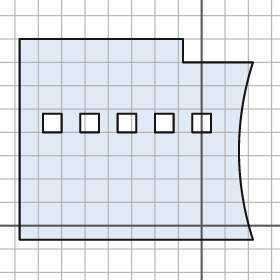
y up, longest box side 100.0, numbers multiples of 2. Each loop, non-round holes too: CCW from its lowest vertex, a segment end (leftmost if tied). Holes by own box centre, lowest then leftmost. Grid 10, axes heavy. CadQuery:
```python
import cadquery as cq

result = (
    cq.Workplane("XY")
    .moveTo(-78.0, -6.0)
    .lineTo(22.0, -6.0)
    .threePointArc((16.0, 32.0), (22.0, 70.0))
    .lineTo(-8.0, 70.0)
    .lineTo(-8.0, 80.0)
    .lineTo(-78.0, 80.0)
    .close()
    .moveTo(-68.0, 40.0)
    .lineTo(-60.0, 40.0)
    .lineTo(-60.0, 48.0)
    .lineTo(-68.0, 48.0)
    .close()
    .moveTo(-52.0, 40.0)
    .lineTo(-44.0, 40.0)
    .lineTo(-44.0, 48.0)
    .lineTo(-52.0, 48.0)
    .close()
    .moveTo(-36.0, 40.0)
    .lineTo(-28.0, 40.0)
    .lineTo(-28.0, 48.0)
    .lineTo(-36.0, 48.0)
    .close()
    .moveTo(-20.0, 40.0)
    .lineTo(-12.0, 40.0)
    .lineTo(-12.0, 48.0)
    .lineTo(-20.0, 48.0)
    .close()
    .moveTo(-4.0, 40.0)
    .lineTo(4.0, 40.0)
    .lineTo(4.0, 48.0)
    .lineTo(-4.0, 48.0)
    .close()
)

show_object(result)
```